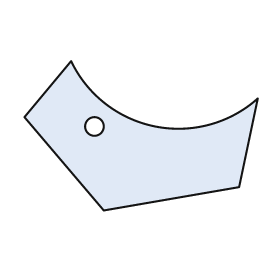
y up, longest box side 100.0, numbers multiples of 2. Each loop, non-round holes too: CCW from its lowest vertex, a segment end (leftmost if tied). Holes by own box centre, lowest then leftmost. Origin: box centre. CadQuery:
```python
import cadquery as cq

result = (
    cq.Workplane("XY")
    .moveTo(-16.0, -32.0)
    .lineTo(42.0, -22.0)
    .lineTo(50.0, 16.0)
    .threePointArc((6.0, 4.0), (-30.0, 32.0))
    .lineTo(-50.0, 8.0)
    .close()
    .moveTo(-20.0, 4.0)
    .circle(4.0)
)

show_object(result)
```